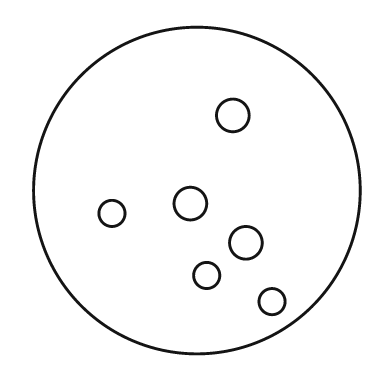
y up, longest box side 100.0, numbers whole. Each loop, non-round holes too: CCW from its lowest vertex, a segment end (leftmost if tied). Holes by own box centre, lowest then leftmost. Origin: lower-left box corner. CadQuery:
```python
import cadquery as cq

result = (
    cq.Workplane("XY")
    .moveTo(50.0, 50.0)
    .circle(50.0)
    .moveTo(73.0, 16.0)
    .circle(4.0)
    .moveTo(53.0, 24.0)
    .circle(4.0)
    .moveTo(65.0, 34.0)
    .circle(5.0)
    .moveTo(24.0, 43.0)
    .circle(4.0)
    .moveTo(48.0, 46.0)
    .circle(5.0)
    .moveTo(61.0, 73.0)
    .circle(5.0)
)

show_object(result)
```